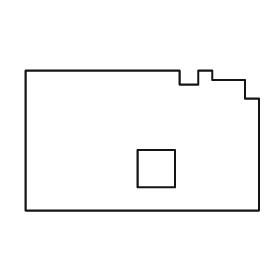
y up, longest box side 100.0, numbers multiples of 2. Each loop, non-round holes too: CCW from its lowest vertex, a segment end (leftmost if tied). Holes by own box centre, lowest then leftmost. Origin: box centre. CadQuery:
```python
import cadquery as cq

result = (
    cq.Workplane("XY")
    .moveTo(-50.0, -30.0)
    .lineTo(50.0, -30.0)
    .lineTo(50.0, 18.0)
    .lineTo(44.0, 18.0)
    .lineTo(44.0, 26.0)
    .lineTo(30.0, 26.0)
    .lineTo(30.0, 30.0)
    .lineTo(24.0, 30.0)
    .lineTo(24.0, 24.0)
    .lineTo(16.0, 24.0)
    .lineTo(16.0, 30.0)
    .lineTo(-50.0, 30.0)
    .close()
    .moveTo(-2.0, -20.0)
    .lineTo(14.0, -20.0)
    .lineTo(14.0, -4.0)
    .lineTo(-2.0, -4.0)
    .close()
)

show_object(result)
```